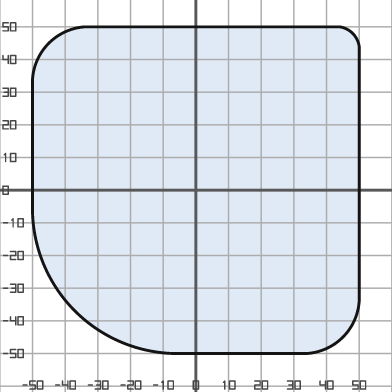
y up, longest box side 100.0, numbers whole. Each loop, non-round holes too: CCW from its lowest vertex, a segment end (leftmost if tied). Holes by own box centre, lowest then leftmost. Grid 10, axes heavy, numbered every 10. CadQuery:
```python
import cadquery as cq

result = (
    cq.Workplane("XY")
    .moveTo(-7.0, -50.0)
    .lineTo(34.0, -50.0)
    .threePointArc((45.0, -45.0), (50.0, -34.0))
    .lineTo(50.0, 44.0)
    .threePointArc((48.0, 48.0), (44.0, 50.0))
    .lineTo(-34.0, 50.0)
    .threePointArc((-45.0, 45.0), (-50.0, 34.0))
    .lineTo(-50.0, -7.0)
    .threePointArc((-37.0, -37.0), (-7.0, -50.0))
    .close()
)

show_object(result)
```